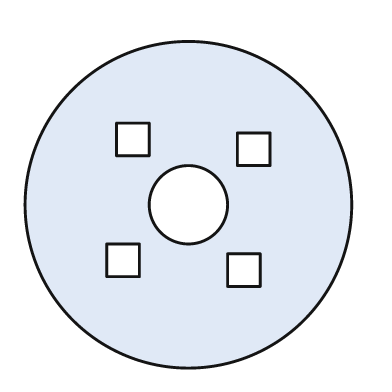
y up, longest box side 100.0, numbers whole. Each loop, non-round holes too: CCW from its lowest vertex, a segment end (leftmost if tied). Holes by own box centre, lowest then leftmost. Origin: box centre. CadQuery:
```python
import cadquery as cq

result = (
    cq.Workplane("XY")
    .moveTo(0.0, 0.0)
    .circle(50.0)
    .moveTo(12.0, -25.0)
    .lineTo(22.0, -25.0)
    .lineTo(22.0, -15.0)
    .lineTo(12.0, -15.0)
    .close()
    .moveTo(-25.0, -22.0)
    .lineTo(-15.0, -22.0)
    .lineTo(-15.0, -12.0)
    .lineTo(-25.0, -12.0)
    .close()
    .moveTo(0.0, 0.0)
    .circle(12.0)
    .moveTo(15.0, 12.0)
    .lineTo(25.0, 12.0)
    .lineTo(25.0, 22.0)
    .lineTo(15.0, 22.0)
    .close()
    .moveTo(-22.0, 15.0)
    .lineTo(-12.0, 15.0)
    .lineTo(-12.0, 25.0)
    .lineTo(-22.0, 25.0)
    .close()
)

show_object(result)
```